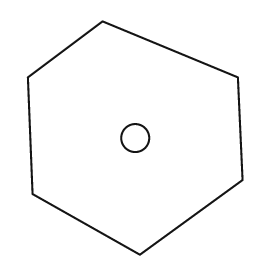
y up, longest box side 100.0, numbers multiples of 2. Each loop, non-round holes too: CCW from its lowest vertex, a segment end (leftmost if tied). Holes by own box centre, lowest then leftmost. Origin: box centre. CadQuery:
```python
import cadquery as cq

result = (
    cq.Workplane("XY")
    .moveTo(2.0, -50.0)
    .lineTo(46.0, -18.0)
    .lineTo(44.0, 26.0)
    .lineTo(-14.0, 50.0)
    .lineTo(-46.0, 26.0)
    .lineTo(-44.0, -24.0)
    .close()
    .moveTo(0.0, 0.0)
    .circle(6.0)
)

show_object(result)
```